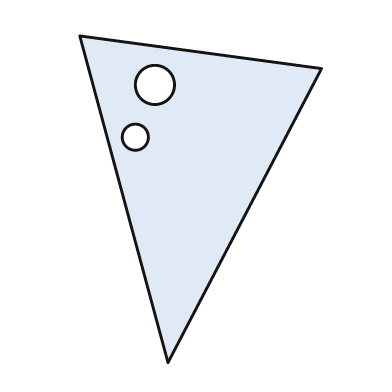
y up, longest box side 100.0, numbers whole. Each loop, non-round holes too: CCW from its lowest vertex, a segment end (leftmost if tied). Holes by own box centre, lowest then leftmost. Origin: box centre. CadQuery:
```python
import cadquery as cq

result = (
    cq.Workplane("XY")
    .moveTo(-10.0, -50.0)
    .lineTo(37.0, 40.0)
    .lineTo(-37.0, 50.0)
    .close()
    .moveTo(-20.0, 19.0)
    .circle(4.0)
    .moveTo(-14.0, 35.0)
    .circle(6.0)
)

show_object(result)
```